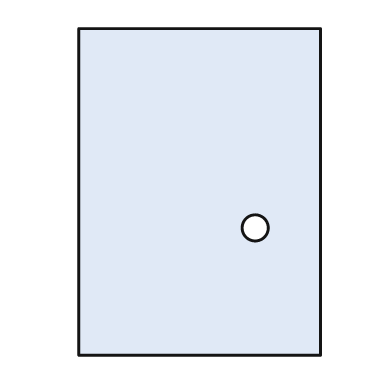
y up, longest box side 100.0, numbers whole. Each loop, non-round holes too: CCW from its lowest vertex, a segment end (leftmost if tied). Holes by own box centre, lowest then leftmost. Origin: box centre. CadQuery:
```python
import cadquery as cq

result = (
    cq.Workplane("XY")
    .moveTo(-37.0, -50.0)
    .lineTo(37.0, -50.0)
    .lineTo(37.0, 50.0)
    .lineTo(-37.0, 50.0)
    .close()
    .moveTo(17.0, -11.0)
    .circle(4.0)
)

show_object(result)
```